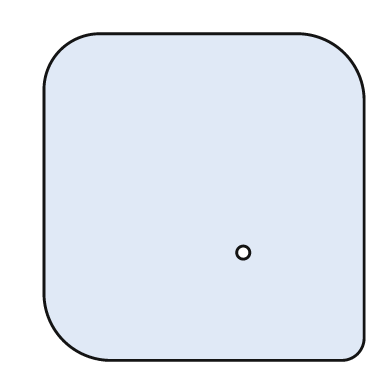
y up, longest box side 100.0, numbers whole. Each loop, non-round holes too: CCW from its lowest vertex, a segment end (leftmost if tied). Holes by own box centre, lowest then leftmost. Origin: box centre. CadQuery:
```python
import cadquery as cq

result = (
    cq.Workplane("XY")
    .moveTo(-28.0, -50.0)
    .lineTo(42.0, -50.0)
    .threePointArc((47.0, -48.0), (49.0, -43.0))
    .lineTo(49.0, 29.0)
    .threePointArc((43.0, 44.0), (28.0, 50.0))
    .lineTo(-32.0, 50.0)
    .threePointArc((-44.0, 45.0), (-49.0, 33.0))
    .lineTo(-49.0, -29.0)
    .threePointArc((-43.0, -44.0), (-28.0, -50.0))
    .close()
    .moveTo(12.0, -17.0)
    .circle(2.0)
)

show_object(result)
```